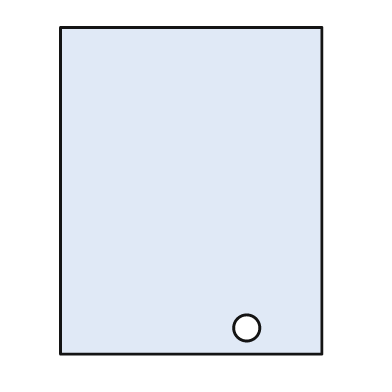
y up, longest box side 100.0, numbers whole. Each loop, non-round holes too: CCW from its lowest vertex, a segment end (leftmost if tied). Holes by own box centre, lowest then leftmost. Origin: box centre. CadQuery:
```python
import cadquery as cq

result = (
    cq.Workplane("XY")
    .moveTo(-40.0, -50.0)
    .lineTo(40.0, -50.0)
    .lineTo(40.0, 50.0)
    .lineTo(-40.0, 50.0)
    .close()
    .moveTo(17.0, -42.0)
    .circle(4.0)
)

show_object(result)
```